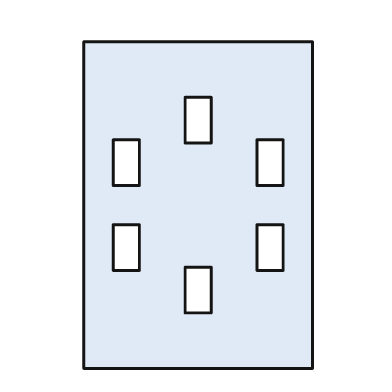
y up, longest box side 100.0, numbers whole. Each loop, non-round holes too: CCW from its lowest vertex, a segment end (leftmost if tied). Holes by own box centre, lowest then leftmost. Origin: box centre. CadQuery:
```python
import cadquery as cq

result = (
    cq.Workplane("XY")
    .moveTo(-35.0, -50.0)
    .lineTo(35.0, -50.0)
    .lineTo(35.0, 50.0)
    .lineTo(-35.0, 50.0)
    .close()
    .moveTo(-4.0, -33.0)
    .lineTo(4.0, -33.0)
    .lineTo(4.0, -19.0)
    .lineTo(-4.0, -19.0)
    .close()
    .moveTo(-26.0, -20.0)
    .lineTo(-18.0, -20.0)
    .lineTo(-18.0, -6.0)
    .lineTo(-26.0, -6.0)
    .close()
    .moveTo(18.0, -20.0)
    .lineTo(26.0, -20.0)
    .lineTo(26.0, -6.0)
    .lineTo(18.0, -6.0)
    .close()
    .moveTo(-26.0, 6.0)
    .lineTo(-18.0, 6.0)
    .lineTo(-18.0, 20.0)
    .lineTo(-26.0, 20.0)
    .close()
    .moveTo(18.0, 6.0)
    .lineTo(26.0, 6.0)
    .lineTo(26.0, 20.0)
    .lineTo(18.0, 20.0)
    .close()
    .moveTo(-4.0, 19.0)
    .lineTo(4.0, 19.0)
    .lineTo(4.0, 33.0)
    .lineTo(-4.0, 33.0)
    .close()
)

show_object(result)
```